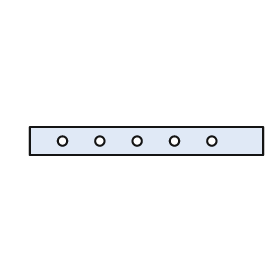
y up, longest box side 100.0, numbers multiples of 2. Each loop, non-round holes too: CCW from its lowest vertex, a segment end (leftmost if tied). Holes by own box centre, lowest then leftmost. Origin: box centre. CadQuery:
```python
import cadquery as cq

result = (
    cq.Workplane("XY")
    .moveTo(-50.0, -6.0)
    .lineTo(50.0, -6.0)
    .lineTo(50.0, 6.0)
    .lineTo(-50.0, 6.0)
    .close()
    .moveTo(-36.0, 0.0)
    .circle(2.0)
    .moveTo(-20.0, 0.0)
    .circle(2.0)
    .moveTo(-4.0, 0.0)
    .circle(2.0)
    .moveTo(12.0, 0.0)
    .circle(2.0)
    .moveTo(28.0, 0.0)
    .circle(2.0)
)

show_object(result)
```